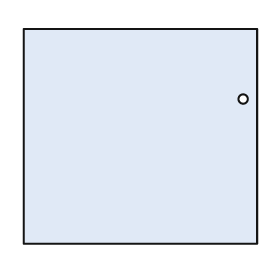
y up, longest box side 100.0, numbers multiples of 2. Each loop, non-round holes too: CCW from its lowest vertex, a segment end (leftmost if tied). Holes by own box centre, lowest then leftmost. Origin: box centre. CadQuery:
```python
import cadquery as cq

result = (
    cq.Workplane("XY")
    .moveTo(-50.0, -46.0)
    .lineTo(50.0, -46.0)
    .lineTo(50.0, 46.0)
    .lineTo(-50.0, 46.0)
    .close()
    .moveTo(44.0, 16.0)
    .circle(2.0)
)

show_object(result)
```